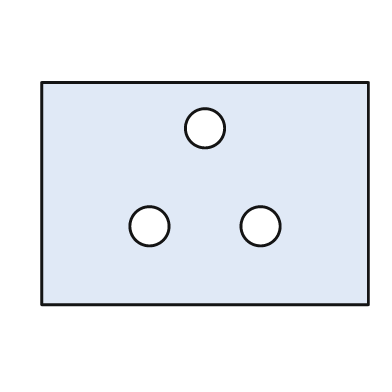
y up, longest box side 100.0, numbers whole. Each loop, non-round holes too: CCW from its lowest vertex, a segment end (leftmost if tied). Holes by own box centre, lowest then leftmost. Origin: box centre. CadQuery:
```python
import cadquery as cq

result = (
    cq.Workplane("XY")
    .moveTo(-50.0, -34.0)
    .lineTo(50.0, -34.0)
    .lineTo(50.0, 34.0)
    .lineTo(-50.0, 34.0)
    .close()
    .moveTo(-17.0, -10.0)
    .circle(6.0)
    .moveTo(17.0, -10.0)
    .circle(6.0)
    .moveTo(0.0, 20.0)
    .circle(6.0)
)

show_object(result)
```